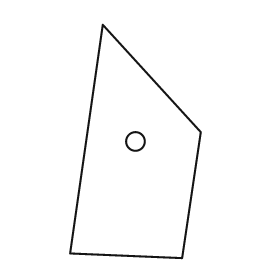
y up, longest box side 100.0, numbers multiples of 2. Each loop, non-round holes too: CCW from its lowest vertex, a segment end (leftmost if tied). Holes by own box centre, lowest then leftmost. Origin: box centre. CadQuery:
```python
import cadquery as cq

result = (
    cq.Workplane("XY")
    .moveTo(20.0, -50.0)
    .lineTo(28.0, 4.0)
    .lineTo(-14.0, 50.0)
    .lineTo(-28.0, -48.0)
    .close()
    .moveTo(0.0, 0.0)
    .circle(4.0)
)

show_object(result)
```